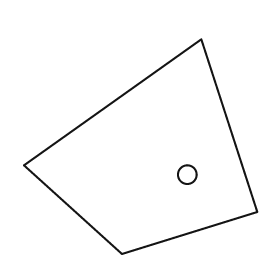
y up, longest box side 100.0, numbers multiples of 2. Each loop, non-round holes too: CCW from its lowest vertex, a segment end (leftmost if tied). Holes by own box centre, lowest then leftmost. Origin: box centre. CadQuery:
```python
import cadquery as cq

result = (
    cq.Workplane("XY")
    .moveTo(-8.0, -46.0)
    .lineTo(50.0, -28.0)
    .lineTo(26.0, 46.0)
    .lineTo(-50.0, -8.0)
    .close()
    .moveTo(20.0, -12.0)
    .circle(4.0)
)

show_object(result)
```